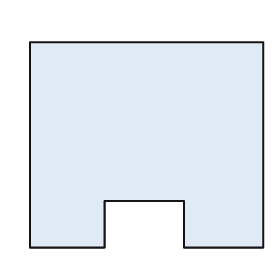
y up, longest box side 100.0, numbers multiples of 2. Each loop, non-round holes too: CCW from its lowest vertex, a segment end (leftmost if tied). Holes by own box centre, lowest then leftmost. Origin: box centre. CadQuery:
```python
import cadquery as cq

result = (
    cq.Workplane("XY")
    .moveTo(-50.0, -44.0)
    .lineTo(-18.0, -44.0)
    .lineTo(-18.0, -24.0)
    .lineTo(16.0, -24.0)
    .lineTo(16.0, -44.0)
    .lineTo(50.0, -44.0)
    .lineTo(50.0, 44.0)
    .lineTo(-50.0, 44.0)
    .close()
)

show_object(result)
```